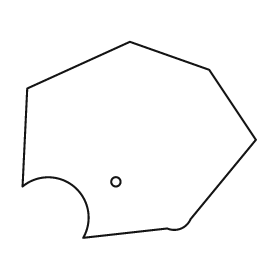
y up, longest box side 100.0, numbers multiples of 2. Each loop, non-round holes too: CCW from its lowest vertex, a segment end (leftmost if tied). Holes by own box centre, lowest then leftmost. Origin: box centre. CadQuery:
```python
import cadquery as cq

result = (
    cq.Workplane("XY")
    .moveTo(-24.0, -42.0)
    .lineTo(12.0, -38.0)
    .threePointArc((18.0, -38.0), (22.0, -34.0))
    .lineTo(50.0, 0.0)
    .lineTo(30.0, 30.0)
    .lineTo(-4.0, 42.0)
    .lineTo(-48.0, 22.0)
    .lineTo(-50.0, -20.0)
    .threePointArc((-28.0, -20.0), (-24.0, -42.0))
    .close()
    .moveTo(-10.0, -18.0)
    .circle(2.0)
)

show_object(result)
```